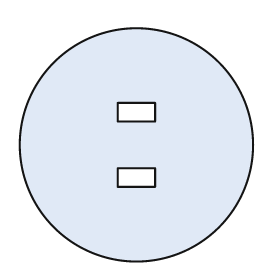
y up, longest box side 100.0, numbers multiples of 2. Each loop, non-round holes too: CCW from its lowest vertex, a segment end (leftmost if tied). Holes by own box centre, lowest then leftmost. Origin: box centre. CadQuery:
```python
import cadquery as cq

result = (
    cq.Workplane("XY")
    .moveTo(0.0, 0.0)
    .circle(50.0)
    .moveTo(-8.0, -18.0)
    .lineTo(8.0, -18.0)
    .lineTo(8.0, -10.0)
    .lineTo(-8.0, -10.0)
    .close()
    .moveTo(-8.0, 10.0)
    .lineTo(8.0, 10.0)
    .lineTo(8.0, 18.0)
    .lineTo(-8.0, 18.0)
    .close()
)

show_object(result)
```